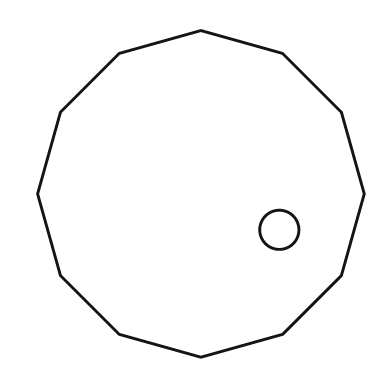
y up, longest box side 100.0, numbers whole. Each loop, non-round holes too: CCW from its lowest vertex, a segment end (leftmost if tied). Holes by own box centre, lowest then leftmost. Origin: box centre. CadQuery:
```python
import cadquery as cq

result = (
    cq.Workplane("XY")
    .moveTo(0.0, -50.0)
    .lineTo(25.0, -43.0)
    .lineTo(43.0, -25.0)
    .lineTo(50.0, 0.0)
    .lineTo(43.0, 25.0)
    .lineTo(25.0, 43.0)
    .lineTo(0.0, 50.0)
    .lineTo(-25.0, 43.0)
    .lineTo(-43.0, 25.0)
    .lineTo(-50.0, 0.0)
    .lineTo(-43.0, -25.0)
    .lineTo(-25.0, -43.0)
    .close()
    .moveTo(24.0, -11.0)
    .circle(6.0)
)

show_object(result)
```